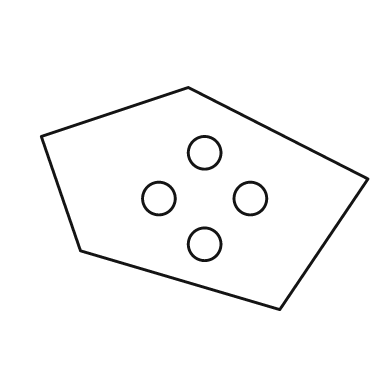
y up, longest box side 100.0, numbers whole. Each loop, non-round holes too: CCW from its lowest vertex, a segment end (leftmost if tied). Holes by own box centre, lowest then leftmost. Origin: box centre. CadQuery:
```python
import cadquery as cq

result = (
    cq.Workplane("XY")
    .moveTo(23.0, -34.0)
    .lineTo(50.0, 6.0)
    .lineTo(-5.0, 34.0)
    .lineTo(-50.0, 19.0)
    .lineTo(-38.0, -16.0)
    .close()
    .moveTo(0.0, -14.0)
    .circle(5.0)
    .moveTo(-14.0, 0.0)
    .circle(5.0)
    .moveTo(14.0, 0.0)
    .circle(5.0)
    .moveTo(0.0, 14.0)
    .circle(5.0)
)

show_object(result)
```